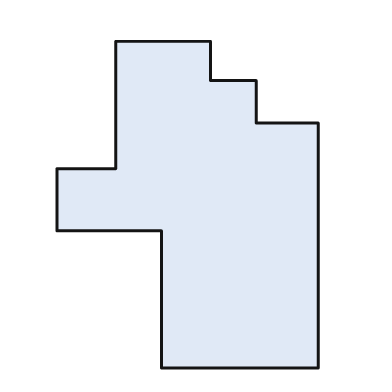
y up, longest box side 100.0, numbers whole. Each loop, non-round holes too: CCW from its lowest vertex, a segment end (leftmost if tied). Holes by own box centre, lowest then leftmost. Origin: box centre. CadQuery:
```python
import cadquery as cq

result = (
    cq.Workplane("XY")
    .moveTo(-8.0, -50.0)
    .lineTo(40.0, -50.0)
    .lineTo(40.0, 25.0)
    .lineTo(21.0, 25.0)
    .lineTo(21.0, 38.0)
    .lineTo(7.0, 38.0)
    .lineTo(7.0, 50.0)
    .lineTo(-22.0, 50.0)
    .lineTo(-22.0, 11.0)
    .lineTo(-40.0, 11.0)
    .lineTo(-40.0, -8.0)
    .lineTo(-8.0, -8.0)
    .close()
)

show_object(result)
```